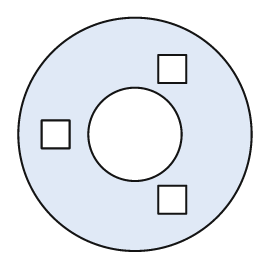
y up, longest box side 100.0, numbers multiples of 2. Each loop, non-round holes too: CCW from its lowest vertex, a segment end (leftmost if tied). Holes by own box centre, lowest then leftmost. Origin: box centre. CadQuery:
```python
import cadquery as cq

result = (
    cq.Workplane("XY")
    .moveTo(0.0, 0.0)
    .circle(50.0)
    .moveTo(10.0, -34.0)
    .lineTo(22.0, -34.0)
    .lineTo(22.0, -22.0)
    .lineTo(10.0, -22.0)
    .close()
    .moveTo(-40.0, -6.0)
    .lineTo(-28.0, -6.0)
    .lineTo(-28.0, 6.0)
    .lineTo(-40.0, 6.0)
    .close()
    .moveTo(0.0, 0.0)
    .circle(20.0)
    .moveTo(10.0, 22.0)
    .lineTo(22.0, 22.0)
    .lineTo(22.0, 34.0)
    .lineTo(10.0, 34.0)
    .close()
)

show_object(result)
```